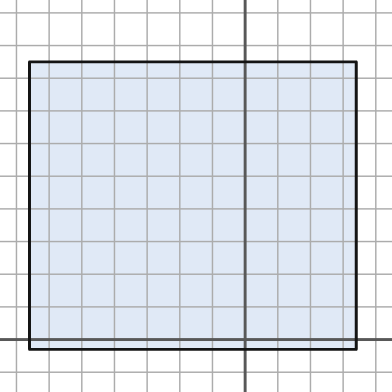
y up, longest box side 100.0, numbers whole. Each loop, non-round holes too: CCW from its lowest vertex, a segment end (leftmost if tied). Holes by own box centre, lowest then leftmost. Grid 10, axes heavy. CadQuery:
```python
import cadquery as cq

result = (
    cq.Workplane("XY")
    .moveTo(-66.0, -3.0)
    .lineTo(34.0, -3.0)
    .lineTo(34.0, 85.0)
    .lineTo(-66.0, 85.0)
    .close()
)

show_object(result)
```